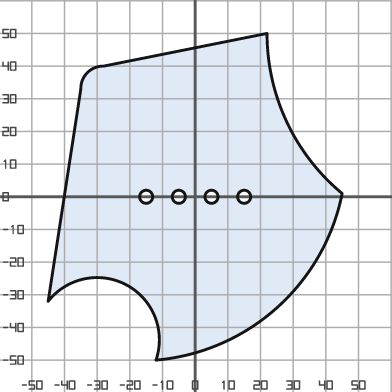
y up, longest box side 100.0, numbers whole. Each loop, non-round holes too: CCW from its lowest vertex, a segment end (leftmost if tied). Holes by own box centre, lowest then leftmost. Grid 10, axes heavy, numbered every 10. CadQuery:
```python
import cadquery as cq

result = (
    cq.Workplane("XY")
    .moveTo(-12.0, -50.0)
    .threePointArc((25.0, -34.0), (45.0, 1.0))
    .threePointArc((28.0, 23.0), (22.0, 50.0))
    .lineTo(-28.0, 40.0)
    .threePointArc((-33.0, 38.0), (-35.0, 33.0))
    .lineTo(-45.0, -32.0)
    .threePointArc((-21.0, -27.0), (-12.0, -50.0))
    .close()
    .moveTo(-15.0, 0.0)
    .circle(2.0)
    .moveTo(-5.0, 0.0)
    .circle(2.0)
    .moveTo(5.0, 0.0)
    .circle(2.0)
    .moveTo(15.0, 0.0)
    .circle(2.0)
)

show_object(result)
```